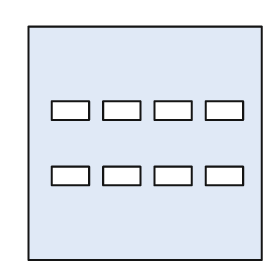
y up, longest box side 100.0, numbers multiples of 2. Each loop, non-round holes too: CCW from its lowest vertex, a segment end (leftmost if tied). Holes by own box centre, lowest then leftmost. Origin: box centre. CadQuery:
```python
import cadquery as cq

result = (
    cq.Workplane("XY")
    .moveTo(-50.0, -50.0)
    .lineTo(50.0, -50.0)
    .lineTo(50.0, 50.0)
    .lineTo(-50.0, 50.0)
    .close()
    .moveTo(-40.0, -18.0)
    .lineTo(-24.0, -18.0)
    .lineTo(-24.0, -10.0)
    .lineTo(-40.0, -10.0)
    .close()
    .moveTo(-18.0, -18.0)
    .lineTo(-2.0, -18.0)
    .lineTo(-2.0, -10.0)
    .lineTo(-18.0, -10.0)
    .close()
    .moveTo(4.0, -18.0)
    .lineTo(20.0, -18.0)
    .lineTo(20.0, -10.0)
    .lineTo(4.0, -10.0)
    .close()
    .moveTo(26.0, -18.0)
    .lineTo(42.0, -18.0)
    .lineTo(42.0, -10.0)
    .lineTo(26.0, -10.0)
    .close()
    .moveTo(-40.0, 10.0)
    .lineTo(-24.0, 10.0)
    .lineTo(-24.0, 18.0)
    .lineTo(-40.0, 18.0)
    .close()
    .moveTo(-18.0, 10.0)
    .lineTo(-2.0, 10.0)
    .lineTo(-2.0, 18.0)
    .lineTo(-18.0, 18.0)
    .close()
    .moveTo(4.0, 10.0)
    .lineTo(20.0, 10.0)
    .lineTo(20.0, 18.0)
    .lineTo(4.0, 18.0)
    .close()
    .moveTo(26.0, 10.0)
    .lineTo(42.0, 10.0)
    .lineTo(42.0, 18.0)
    .lineTo(26.0, 18.0)
    .close()
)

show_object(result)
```